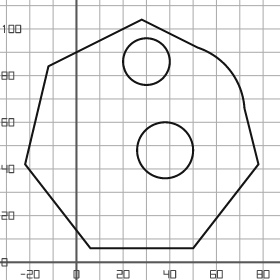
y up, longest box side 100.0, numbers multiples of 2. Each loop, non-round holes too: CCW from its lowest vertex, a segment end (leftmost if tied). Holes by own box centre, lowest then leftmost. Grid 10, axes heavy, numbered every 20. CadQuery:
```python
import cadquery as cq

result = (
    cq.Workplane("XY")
    .moveTo(6.0, 6.0)
    .lineTo(50.0, 6.0)
    .lineTo(78.0, 42.0)
    .lineTo(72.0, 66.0)
    .threePointArc((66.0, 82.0), (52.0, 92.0))
    .lineTo(28.0, 104.0)
    .lineTo(-12.0, 84.0)
    .lineTo(-22.0, 42.0)
    .close()
    .moveTo(38.0, 48.0)
    .circle(12.0)
    .moveTo(30.0, 86.0)
    .circle(10.0)
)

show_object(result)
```